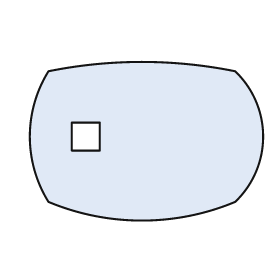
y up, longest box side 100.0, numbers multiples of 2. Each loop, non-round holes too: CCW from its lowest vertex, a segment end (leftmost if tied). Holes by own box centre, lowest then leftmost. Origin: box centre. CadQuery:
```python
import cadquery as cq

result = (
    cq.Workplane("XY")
    .moveTo(-42.0, -26.0)
    .threePointArc((-2.0, -34.0), (38.0, -26.0))
    .threePointArc((50.0, 2.0), (38.0, 30.0))
    .threePointArc((-2.0, 34.0), (-42.0, 30.0))
    .threePointArc((-50.0, 2.0), (-42.0, -26.0))
    .close()
    .moveTo(-32.0, -4.0)
    .lineTo(-20.0, -4.0)
    .lineTo(-20.0, 8.0)
    .lineTo(-32.0, 8.0)
    .close()
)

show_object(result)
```